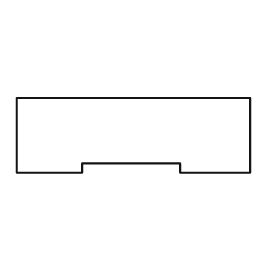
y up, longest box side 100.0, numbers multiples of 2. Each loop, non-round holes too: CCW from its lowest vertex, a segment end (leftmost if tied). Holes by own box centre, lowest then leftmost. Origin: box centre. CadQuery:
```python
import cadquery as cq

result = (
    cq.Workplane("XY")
    .moveTo(-50.0, -16.0)
    .lineTo(-22.0, -16.0)
    .lineTo(-22.0, -12.0)
    .lineTo(20.0, -12.0)
    .lineTo(20.0, -16.0)
    .lineTo(50.0, -16.0)
    .lineTo(50.0, 16.0)
    .lineTo(-50.0, 16.0)
    .close()
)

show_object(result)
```